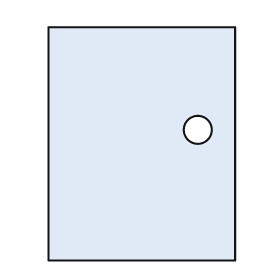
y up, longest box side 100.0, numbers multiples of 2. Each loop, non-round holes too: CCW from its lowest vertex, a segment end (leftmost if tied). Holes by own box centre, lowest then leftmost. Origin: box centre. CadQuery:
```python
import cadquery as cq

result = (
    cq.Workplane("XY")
    .moveTo(-40.0, -50.0)
    .lineTo(40.0, -50.0)
    .lineTo(40.0, 50.0)
    .lineTo(-40.0, 50.0)
    .close()
    .moveTo(24.0, 6.0)
    .circle(6.0)
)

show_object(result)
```